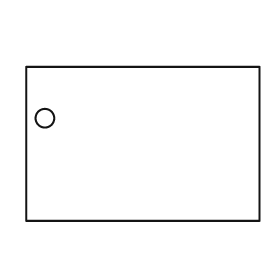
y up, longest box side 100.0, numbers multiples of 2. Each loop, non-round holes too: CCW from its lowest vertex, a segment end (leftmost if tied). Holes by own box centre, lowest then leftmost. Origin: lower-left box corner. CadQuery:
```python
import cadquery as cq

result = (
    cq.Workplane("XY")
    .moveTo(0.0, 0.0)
    .lineTo(100.0, 0.0)
    .lineTo(100.0, 66.0)
    .lineTo(0.0, 66.0)
    .close()
    .moveTo(8.0, 44.0)
    .circle(4.0)
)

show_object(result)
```